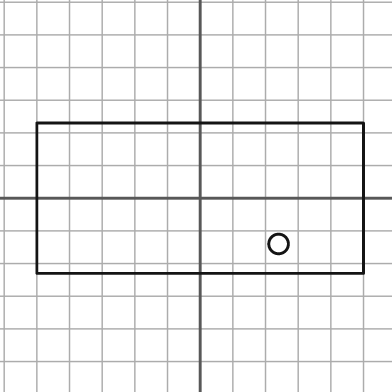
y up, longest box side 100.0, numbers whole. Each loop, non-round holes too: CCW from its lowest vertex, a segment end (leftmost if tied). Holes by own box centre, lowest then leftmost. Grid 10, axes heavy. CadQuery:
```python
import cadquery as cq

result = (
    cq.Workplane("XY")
    .moveTo(-50.0, -23.0)
    .lineTo(50.0, -23.0)
    .lineTo(50.0, 23.0)
    .lineTo(-50.0, 23.0)
    .close()
    .moveTo(24.0, -14.0)
    .circle(3.0)
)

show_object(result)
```